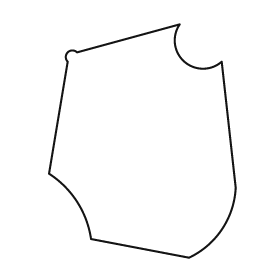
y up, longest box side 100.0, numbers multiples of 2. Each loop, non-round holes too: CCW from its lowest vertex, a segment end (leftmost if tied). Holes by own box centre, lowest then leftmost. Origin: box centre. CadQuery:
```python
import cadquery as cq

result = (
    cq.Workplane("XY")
    .moveTo(20.0, -50.0)
    .threePointArc((34.0, -38.0), (40.0, -20.0))
    .lineTo(34.0, 34.0)
    .threePointArc((18.0, 34.0), (16.0, 50.0))
    .lineTo(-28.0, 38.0)
    .threePointArc((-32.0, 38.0), (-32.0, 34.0))
    .lineTo(-40.0, -14.0)
    .threePointArc((-28.0, -26.0), (-22.0, -42.0))
    .close()
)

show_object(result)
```